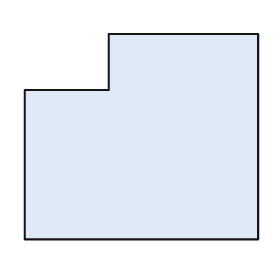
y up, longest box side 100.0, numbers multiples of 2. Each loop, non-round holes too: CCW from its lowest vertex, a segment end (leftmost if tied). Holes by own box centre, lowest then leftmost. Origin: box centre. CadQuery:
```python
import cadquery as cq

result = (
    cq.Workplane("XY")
    .moveTo(-50.0, -44.0)
    .lineTo(50.0, -44.0)
    .lineTo(50.0, 44.0)
    .lineTo(-14.0, 44.0)
    .lineTo(-14.0, 20.0)
    .lineTo(-50.0, 20.0)
    .close()
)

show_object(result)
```